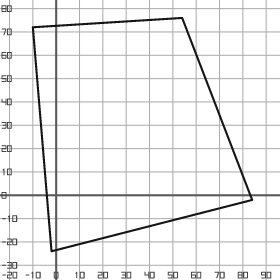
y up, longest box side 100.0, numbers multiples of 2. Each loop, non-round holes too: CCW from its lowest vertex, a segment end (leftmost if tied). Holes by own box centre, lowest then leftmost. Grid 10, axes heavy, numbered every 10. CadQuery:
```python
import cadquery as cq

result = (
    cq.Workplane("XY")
    .moveTo(-2.0, -24.0)
    .lineTo(84.0, -2.0)
    .lineTo(54.0, 76.0)
    .lineTo(-10.0, 72.0)
    .close()
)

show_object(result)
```